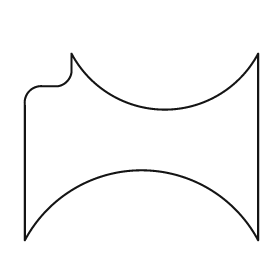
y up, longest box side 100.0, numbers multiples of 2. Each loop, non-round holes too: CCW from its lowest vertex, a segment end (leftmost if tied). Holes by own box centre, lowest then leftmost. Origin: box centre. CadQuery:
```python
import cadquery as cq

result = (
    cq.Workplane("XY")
    .moveTo(-50.0, -40.0)
    .threePointArc((0.0, -10.0), (50.0, -40.0))
    .lineTo(50.0, 40.0)
    .threePointArc((10.0, 16.0), (-30.0, 40.0))
    .lineTo(-30.0, 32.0)
    .threePointArc((-32.0, 28.0), (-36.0, 26.0))
    .lineTo(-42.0, 26.0)
    .threePointArc((-48.0, 24.0), (-50.0, 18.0))
    .close()
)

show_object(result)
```